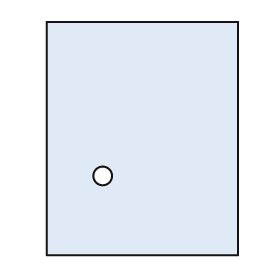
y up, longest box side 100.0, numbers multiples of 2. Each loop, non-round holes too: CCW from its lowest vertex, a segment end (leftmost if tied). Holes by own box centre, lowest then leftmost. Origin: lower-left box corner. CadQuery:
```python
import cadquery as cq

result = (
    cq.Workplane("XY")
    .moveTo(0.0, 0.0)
    .lineTo(82.0, 0.0)
    .lineTo(82.0, 100.0)
    .lineTo(0.0, 100.0)
    .close()
    .moveTo(24.0, 34.0)
    .circle(4.0)
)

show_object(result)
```